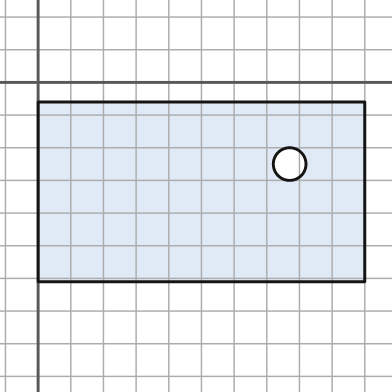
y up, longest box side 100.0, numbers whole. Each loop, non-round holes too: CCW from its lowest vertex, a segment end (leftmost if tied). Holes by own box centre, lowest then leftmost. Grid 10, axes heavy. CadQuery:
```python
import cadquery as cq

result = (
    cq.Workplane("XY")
    .moveTo(0.0, -61.0)
    .lineTo(100.0, -61.0)
    .lineTo(100.0, -6.0)
    .lineTo(0.0, -6.0)
    .close()
    .moveTo(77.0, -25.0)
    .circle(5.0)
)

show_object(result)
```